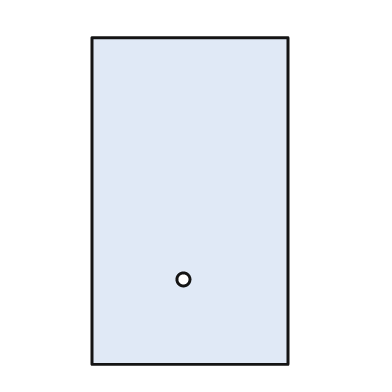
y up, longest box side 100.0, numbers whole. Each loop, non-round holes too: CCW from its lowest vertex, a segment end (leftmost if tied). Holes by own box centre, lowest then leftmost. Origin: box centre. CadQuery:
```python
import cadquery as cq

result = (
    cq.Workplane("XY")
    .moveTo(-30.0, -50.0)
    .lineTo(30.0, -50.0)
    .lineTo(30.0, 50.0)
    .lineTo(-30.0, 50.0)
    .close()
    .moveTo(-2.0, -24.0)
    .circle(2.0)
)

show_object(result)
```